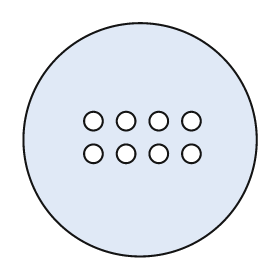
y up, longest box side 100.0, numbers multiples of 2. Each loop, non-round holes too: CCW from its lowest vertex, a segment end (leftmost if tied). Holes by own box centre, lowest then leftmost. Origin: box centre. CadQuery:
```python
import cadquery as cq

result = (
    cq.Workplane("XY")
    .moveTo(0.0, 0.0)
    .circle(50.0)
    .moveTo(-20.0, -6.0)
    .circle(4.0)
    .moveTo(-6.0, -6.0)
    .circle(4.0)
    .moveTo(8.0, -6.0)
    .circle(4.0)
    .moveTo(22.0, -6.0)
    .circle(4.0)
    .moveTo(-20.0, 8.0)
    .circle(4.0)
    .moveTo(-6.0, 8.0)
    .circle(4.0)
    .moveTo(8.0, 8.0)
    .circle(4.0)
    .moveTo(22.0, 8.0)
    .circle(4.0)
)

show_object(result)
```